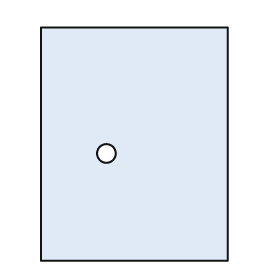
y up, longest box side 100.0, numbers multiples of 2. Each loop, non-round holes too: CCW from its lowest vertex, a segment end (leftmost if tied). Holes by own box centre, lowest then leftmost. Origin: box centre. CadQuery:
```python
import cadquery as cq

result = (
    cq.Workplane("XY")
    .moveTo(-40.0, -50.0)
    .lineTo(40.0, -50.0)
    .lineTo(40.0, 50.0)
    .lineTo(-40.0, 50.0)
    .close()
    .moveTo(-12.0, -4.0)
    .circle(4.0)
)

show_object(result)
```